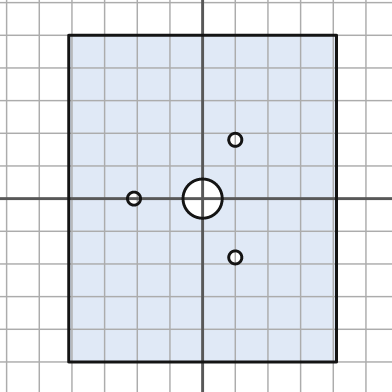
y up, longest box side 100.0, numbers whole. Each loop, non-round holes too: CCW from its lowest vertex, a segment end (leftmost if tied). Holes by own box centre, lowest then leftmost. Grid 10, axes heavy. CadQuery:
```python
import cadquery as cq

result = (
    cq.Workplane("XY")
    .moveTo(-41.0, -50.0)
    .lineTo(41.0, -50.0)
    .lineTo(41.0, 50.0)
    .lineTo(-41.0, 50.0)
    .close()
    .moveTo(10.0, -18.0)
    .circle(2.0)
    .moveTo(-21.0, 0.0)
    .circle(2.0)
    .moveTo(0.0, 0.0)
    .circle(6.0)
    .moveTo(10.0, 18.0)
    .circle(2.0)
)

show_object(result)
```